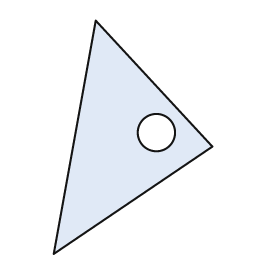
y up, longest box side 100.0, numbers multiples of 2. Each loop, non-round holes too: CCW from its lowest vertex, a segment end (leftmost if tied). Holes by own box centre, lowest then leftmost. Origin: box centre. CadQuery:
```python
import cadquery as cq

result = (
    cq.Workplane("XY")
    .moveTo(-34.0, -50.0)
    .lineTo(34.0, -4.0)
    .lineTo(-16.0, 50.0)
    .close()
    .moveTo(10.0, 2.0)
    .circle(8.0)
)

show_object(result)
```